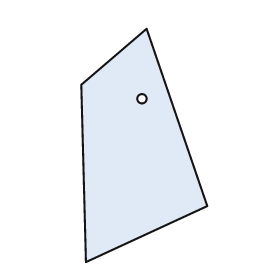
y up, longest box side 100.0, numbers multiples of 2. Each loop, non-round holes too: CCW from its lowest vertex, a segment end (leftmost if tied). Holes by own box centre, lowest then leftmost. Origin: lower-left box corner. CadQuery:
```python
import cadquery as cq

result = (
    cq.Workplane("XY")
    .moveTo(2.0, 0.0)
    .lineTo(54.0, 24.0)
    .lineTo(28.0, 100.0)
    .lineTo(0.0, 76.0)
    .close()
    .moveTo(26.0, 70.0)
    .circle(2.0)
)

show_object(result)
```